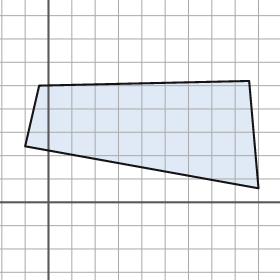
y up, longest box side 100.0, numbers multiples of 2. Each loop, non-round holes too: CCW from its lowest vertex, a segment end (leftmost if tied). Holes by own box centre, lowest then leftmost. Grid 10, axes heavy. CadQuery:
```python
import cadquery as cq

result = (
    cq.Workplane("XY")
    .moveTo(90.0, 6.0)
    .lineTo(86.0, 52.0)
    .lineTo(-4.0, 50.0)
    .lineTo(-10.0, 24.0)
    .close()
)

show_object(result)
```